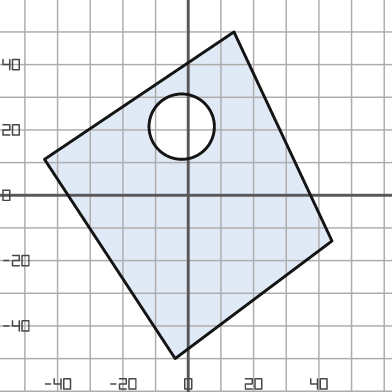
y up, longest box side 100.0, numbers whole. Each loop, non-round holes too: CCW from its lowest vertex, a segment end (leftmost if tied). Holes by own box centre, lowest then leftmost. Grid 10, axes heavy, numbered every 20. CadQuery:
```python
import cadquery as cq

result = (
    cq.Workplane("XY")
    .moveTo(-4.0, -50.0)
    .lineTo(44.0, -14.0)
    .lineTo(14.0, 50.0)
    .lineTo(-44.0, 11.0)
    .close()
    .moveTo(-2.0, 21.0)
    .circle(10.0)
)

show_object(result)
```